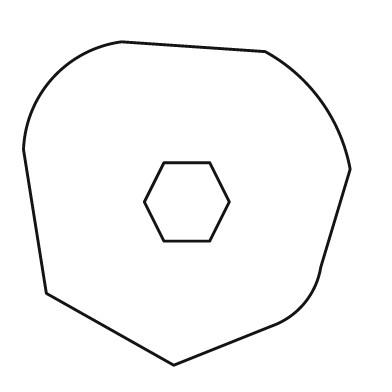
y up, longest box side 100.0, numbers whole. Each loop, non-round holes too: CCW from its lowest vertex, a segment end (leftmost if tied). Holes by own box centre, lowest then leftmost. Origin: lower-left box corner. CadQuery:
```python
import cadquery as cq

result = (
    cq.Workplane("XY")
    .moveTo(46.0, 0.0)
    .lineTo(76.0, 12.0)
    .threePointArc((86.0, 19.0), (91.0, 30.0))
    .lineTo(100.0, 60.0)
    .threePointArc((91.0, 81.0), (74.0, 96.0))
    .lineTo(30.0, 99.0)
    .threePointArc((9.0, 88.0), (0.0, 66.0))
    .lineTo(7.0, 22.0)
    .close()
    .moveTo(43.0, 38.0)
    .lineTo(57.0, 38.0)
    .lineTo(63.0, 50.0)
    .lineTo(57.0, 62.0)
    .lineTo(43.0, 62.0)
    .lineTo(37.0, 50.0)
    .close()
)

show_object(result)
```